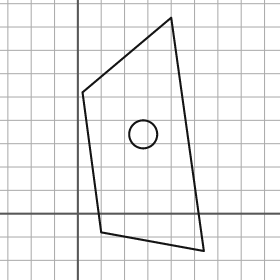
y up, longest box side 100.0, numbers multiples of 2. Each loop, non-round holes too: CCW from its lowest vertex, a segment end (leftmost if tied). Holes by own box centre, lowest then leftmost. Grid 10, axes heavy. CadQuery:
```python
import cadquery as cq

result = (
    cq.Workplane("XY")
    .moveTo(54.0, -16.0)
    .lineTo(40.0, 84.0)
    .lineTo(2.0, 52.0)
    .lineTo(10.0, -8.0)
    .close()
    .moveTo(28.0, 34.0)
    .circle(6.0)
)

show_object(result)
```